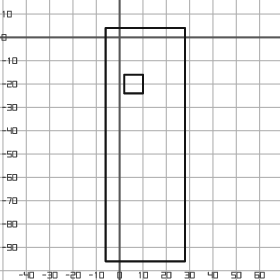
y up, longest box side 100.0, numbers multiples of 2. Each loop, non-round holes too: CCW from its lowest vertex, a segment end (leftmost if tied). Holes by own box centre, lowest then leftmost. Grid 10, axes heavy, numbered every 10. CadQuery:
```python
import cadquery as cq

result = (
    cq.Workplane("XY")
    .moveTo(-6.0, -96.0)
    .lineTo(28.0, -96.0)
    .lineTo(28.0, 4.0)
    .lineTo(-6.0, 4.0)
    .close()
    .moveTo(2.0, -24.0)
    .lineTo(10.0, -24.0)
    .lineTo(10.0, -16.0)
    .lineTo(2.0, -16.0)
    .close()
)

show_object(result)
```